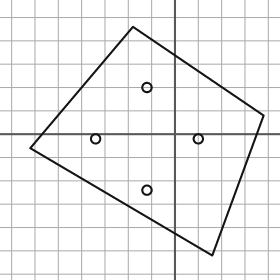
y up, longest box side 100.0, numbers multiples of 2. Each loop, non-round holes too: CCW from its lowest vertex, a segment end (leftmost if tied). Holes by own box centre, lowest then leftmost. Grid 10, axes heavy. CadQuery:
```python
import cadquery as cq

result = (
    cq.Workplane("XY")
    .moveTo(16.0, -52.0)
    .lineTo(38.0, 8.0)
    .lineTo(-18.0, 46.0)
    .lineTo(-62.0, -6.0)
    .close()
    .moveTo(-12.0, -24.0)
    .circle(2.0)
    .moveTo(-34.0, -2.0)
    .circle(2.0)
    .moveTo(10.0, -2.0)
    .circle(2.0)
    .moveTo(-12.0, 20.0)
    .circle(2.0)
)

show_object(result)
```